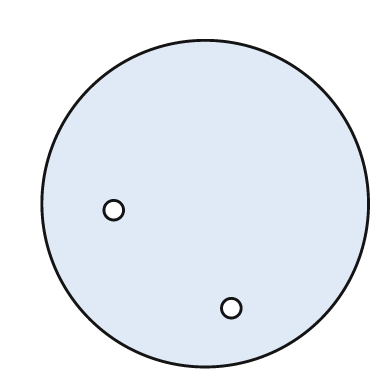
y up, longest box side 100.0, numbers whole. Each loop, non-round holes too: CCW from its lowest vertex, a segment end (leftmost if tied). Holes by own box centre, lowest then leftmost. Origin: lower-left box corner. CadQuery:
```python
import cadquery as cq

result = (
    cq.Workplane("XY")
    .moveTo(50.0, 50.0)
    .circle(50.0)
    .moveTo(58.0, 18.0)
    .circle(3.0)
    .moveTo(22.0, 48.0)
    .circle(3.0)
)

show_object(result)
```